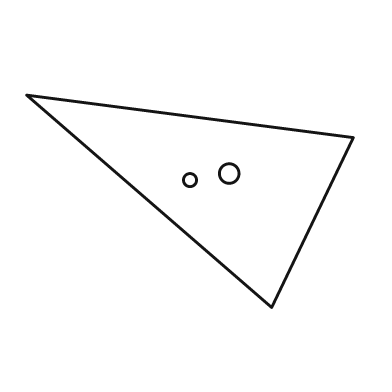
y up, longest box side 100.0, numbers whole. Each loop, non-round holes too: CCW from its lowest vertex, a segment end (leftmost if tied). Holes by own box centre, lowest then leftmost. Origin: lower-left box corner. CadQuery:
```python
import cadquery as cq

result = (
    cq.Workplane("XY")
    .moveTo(75.0, 0.0)
    .lineTo(100.0, 52.0)
    .lineTo(0.0, 65.0)
    .close()
    .moveTo(50.0, 39.0)
    .circle(2.0)
    .moveTo(62.0, 41.0)
    .circle(3.0)
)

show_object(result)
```